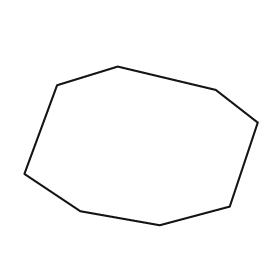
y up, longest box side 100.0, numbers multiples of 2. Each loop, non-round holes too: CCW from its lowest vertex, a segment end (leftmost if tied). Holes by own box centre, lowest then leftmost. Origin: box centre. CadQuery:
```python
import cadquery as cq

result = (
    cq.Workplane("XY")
    .moveTo(8.0, -34.0)
    .lineTo(38.0, -26.0)
    .lineTo(50.0, 10.0)
    .lineTo(32.0, 24.0)
    .lineTo(-10.0, 34.0)
    .lineTo(-36.0, 26.0)
    .lineTo(-50.0, -12.0)
    .lineTo(-26.0, -28.0)
    .close()
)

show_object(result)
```